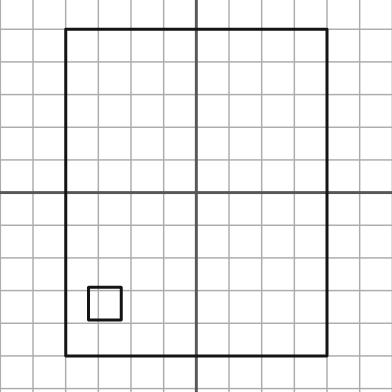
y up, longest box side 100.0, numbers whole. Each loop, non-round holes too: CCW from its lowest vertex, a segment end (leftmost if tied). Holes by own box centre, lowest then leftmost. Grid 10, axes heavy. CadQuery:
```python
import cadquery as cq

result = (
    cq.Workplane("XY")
    .moveTo(-40.0, -50.0)
    .lineTo(40.0, -50.0)
    .lineTo(40.0, 50.0)
    .lineTo(-40.0, 50.0)
    .close()
    .moveTo(-33.0, -39.0)
    .lineTo(-23.0, -39.0)
    .lineTo(-23.0, -29.0)
    .lineTo(-33.0, -29.0)
    .close()
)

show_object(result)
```